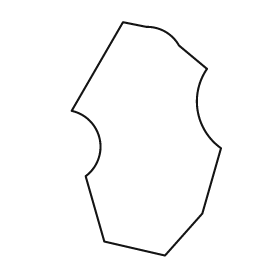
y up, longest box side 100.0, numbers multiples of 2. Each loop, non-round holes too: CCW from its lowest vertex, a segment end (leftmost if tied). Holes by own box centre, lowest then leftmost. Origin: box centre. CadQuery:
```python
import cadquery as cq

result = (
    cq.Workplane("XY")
    .moveTo(8.0, -50.0)
    .lineTo(24.0, -32.0)
    .lineTo(32.0, -4.0)
    .threePointArc((22.0, 12.0), (26.0, 30.0))
    .lineTo(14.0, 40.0)
    .threePointArc((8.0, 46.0), (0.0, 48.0))
    .lineTo(-10.0, 50.0)
    .lineTo(-32.0, 12.0)
    .threePointArc((-20.0, 0.0), (-26.0, -16.0))
    .lineTo(-18.0, -44.0)
    .close()
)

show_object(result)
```